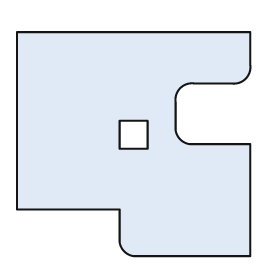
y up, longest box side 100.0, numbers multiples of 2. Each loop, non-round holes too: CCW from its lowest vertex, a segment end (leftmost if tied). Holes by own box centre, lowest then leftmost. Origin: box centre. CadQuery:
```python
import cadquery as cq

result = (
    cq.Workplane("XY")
    .moveTo(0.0, -48.0)
    .lineTo(50.0, -48.0)
    .lineTo(50.0, 0.0)
    .lineTo(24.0, 0.0)
    .threePointArc((20.0, 2.0), (18.0, 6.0))
    .lineTo(18.0, 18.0)
    .threePointArc((20.0, 24.0), (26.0, 26.0))
    .lineTo(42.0, 26.0)
    .threePointArc((48.0, 28.0), (50.0, 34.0))
    .lineTo(50.0, 48.0)
    .lineTo(-50.0, 48.0)
    .lineTo(-50.0, -28.0)
    .lineTo(-6.0, -28.0)
    .lineTo(-6.0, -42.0)
    .threePointArc((-4.0, -46.0), (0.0, -48.0))
    .close()
    .moveTo(-6.0, -2.0)
    .lineTo(6.0, -2.0)
    .lineTo(6.0, 10.0)
    .lineTo(-6.0, 10.0)
    .close()
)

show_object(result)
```